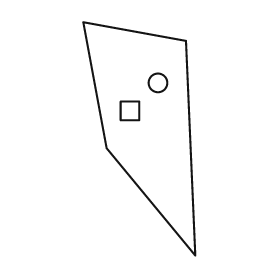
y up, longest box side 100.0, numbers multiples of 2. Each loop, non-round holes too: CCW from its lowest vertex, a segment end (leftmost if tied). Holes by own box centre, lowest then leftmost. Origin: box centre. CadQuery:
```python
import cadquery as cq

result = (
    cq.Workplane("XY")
    .moveTo(24.0, -50.0)
    .lineTo(20.0, 42.0)
    .lineTo(-24.0, 50.0)
    .lineTo(-14.0, -4.0)
    .close()
    .moveTo(-8.0, 8.0)
    .lineTo(0.0, 8.0)
    .lineTo(0.0, 16.0)
    .lineTo(-8.0, 16.0)
    .close()
    .moveTo(8.0, 24.0)
    .circle(4.0)
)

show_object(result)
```